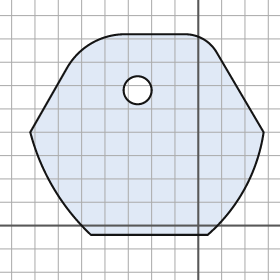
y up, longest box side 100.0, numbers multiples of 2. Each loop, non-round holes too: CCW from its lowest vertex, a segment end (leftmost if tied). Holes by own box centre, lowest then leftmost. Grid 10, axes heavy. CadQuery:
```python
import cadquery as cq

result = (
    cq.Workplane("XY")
    .moveTo(-46.0, -4.0)
    .lineTo(4.0, -4.0)
    .threePointArc((20.0, 16.0), (28.0, 40.0))
    .lineTo(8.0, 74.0)
    .threePointArc((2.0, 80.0), (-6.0, 82.0))
    .lineTo(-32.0, 82.0)
    .threePointArc((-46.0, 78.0), (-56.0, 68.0))
    .lineTo(-72.0, 40.0)
    .threePointArc((-62.0, 16.0), (-46.0, -4.0))
    .close()
    .moveTo(-26.0, 58.0)
    .circle(6.0)
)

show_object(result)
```